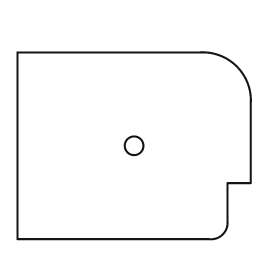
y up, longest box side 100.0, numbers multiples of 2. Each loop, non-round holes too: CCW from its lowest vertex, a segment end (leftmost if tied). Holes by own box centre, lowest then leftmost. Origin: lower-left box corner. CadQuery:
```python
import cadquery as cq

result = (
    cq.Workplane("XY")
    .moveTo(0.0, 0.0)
    .lineTo(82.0, 0.0)
    .threePointArc((88.0, 2.0), (90.0, 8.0))
    .lineTo(90.0, 24.0)
    .lineTo(100.0, 24.0)
    .lineTo(100.0, 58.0)
    .threePointArc((94.0, 74.0), (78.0, 80.0))
    .lineTo(0.0, 80.0)
    .close()
    .moveTo(50.0, 40.0)
    .circle(4.0)
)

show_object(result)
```